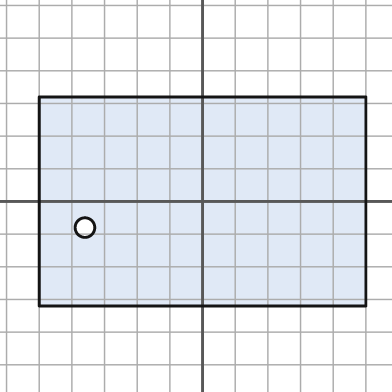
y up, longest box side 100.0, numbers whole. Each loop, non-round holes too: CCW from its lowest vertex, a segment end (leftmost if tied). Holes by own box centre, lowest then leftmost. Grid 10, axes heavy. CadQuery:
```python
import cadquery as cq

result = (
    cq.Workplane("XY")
    .moveTo(-50.0, -32.0)
    .lineTo(50.0, -32.0)
    .lineTo(50.0, 32.0)
    .lineTo(-50.0, 32.0)
    .close()
    .moveTo(-36.0, -8.0)
    .circle(3.0)
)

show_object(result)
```